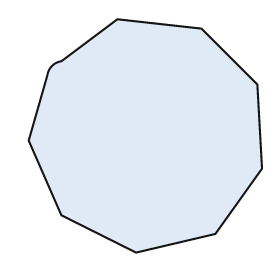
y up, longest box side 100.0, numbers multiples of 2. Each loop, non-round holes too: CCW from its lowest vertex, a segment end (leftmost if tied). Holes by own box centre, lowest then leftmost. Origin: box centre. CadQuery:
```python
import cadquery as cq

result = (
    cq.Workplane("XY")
    .moveTo(-4.0, -50.0)
    .lineTo(30.0, -42.0)
    .lineTo(50.0, -14.0)
    .lineTo(48.0, 22.0)
    .lineTo(24.0, 46.0)
    .lineTo(-12.0, 50.0)
    .lineTo(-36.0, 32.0)
    .threePointArc((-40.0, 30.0), (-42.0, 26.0))
    .lineTo(-50.0, -2.0)
    .lineTo(-36.0, -34.0)
    .close()
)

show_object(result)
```